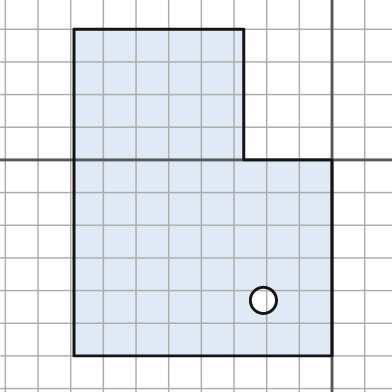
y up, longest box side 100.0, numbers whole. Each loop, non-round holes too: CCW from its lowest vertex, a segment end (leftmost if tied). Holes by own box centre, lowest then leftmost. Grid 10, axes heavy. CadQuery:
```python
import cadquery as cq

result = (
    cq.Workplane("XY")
    .moveTo(-79.0, -60.0)
    .lineTo(0.0, -60.0)
    .lineTo(0.0, 0.0)
    .lineTo(-27.0, 0.0)
    .lineTo(-27.0, 40.0)
    .lineTo(-79.0, 40.0)
    .close()
    .moveTo(-21.0, -43.0)
    .circle(4.0)
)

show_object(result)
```